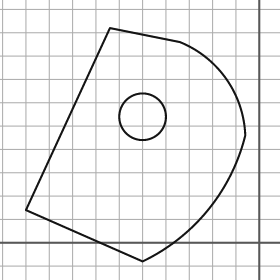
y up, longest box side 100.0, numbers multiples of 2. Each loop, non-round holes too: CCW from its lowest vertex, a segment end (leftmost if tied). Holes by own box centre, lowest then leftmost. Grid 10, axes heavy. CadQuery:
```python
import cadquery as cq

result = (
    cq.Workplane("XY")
    .moveTo(-50.0, -8.0)
    .threePointArc((-22.0, 14.0), (-6.0, 46.0))
    .threePointArc((-14.0, 70.0), (-34.0, 86.0))
    .lineTo(-64.0, 92.0)
    .lineTo(-100.0, 14.0)
    .close()
    .moveTo(-50.0, 54.0)
    .circle(10.0)
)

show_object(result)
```